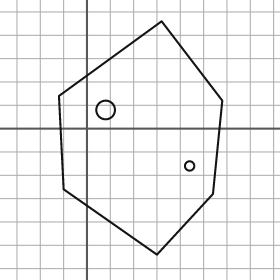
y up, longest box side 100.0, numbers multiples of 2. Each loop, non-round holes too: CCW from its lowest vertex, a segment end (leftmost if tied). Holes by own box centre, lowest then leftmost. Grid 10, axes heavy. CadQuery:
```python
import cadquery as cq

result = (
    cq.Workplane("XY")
    .moveTo(30.0, -54.0)
    .lineTo(54.0, -28.0)
    .lineTo(58.0, 12.0)
    .lineTo(32.0, 46.0)
    .lineTo(-12.0, 14.0)
    .lineTo(-10.0, -26.0)
    .close()
    .moveTo(44.0, -16.0)
    .circle(2.0)
    .moveTo(8.0, 8.0)
    .circle(4.0)
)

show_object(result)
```